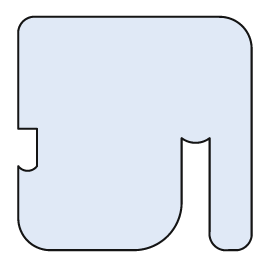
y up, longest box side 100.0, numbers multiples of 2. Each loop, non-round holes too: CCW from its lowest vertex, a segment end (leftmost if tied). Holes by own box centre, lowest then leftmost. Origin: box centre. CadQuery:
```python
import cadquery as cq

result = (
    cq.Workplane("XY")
    .moveTo(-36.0, -50.0)
    .lineTo(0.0, -50.0)
    .threePointArc((14.0, -44.0), (20.0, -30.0))
    .lineTo(20.0, -2.0)
    .threePointArc((26.0, -4.0), (32.0, -2.0))
    .lineTo(32.0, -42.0)
    .threePointArc((34.0, -48.0), (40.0, -50.0))
    .lineTo(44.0, -50.0)
    .threePointArc((48.0, -48.0), (50.0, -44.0))
    .lineTo(50.0, 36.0)
    .threePointArc((46.0, 46.0), (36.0, 50.0))
    .lineTo(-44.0, 50.0)
    .threePointArc((-48.0, 48.0), (-50.0, 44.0))
    .lineTo(-50.0, 2.0)
    .lineTo(-42.0, 2.0)
    .lineTo(-42.0, -14.0)
    .threePointArc((-46.0, -16.0), (-50.0, -14.0))
    .lineTo(-50.0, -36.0)
    .threePointArc((-46.0, -46.0), (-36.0, -50.0))
    .close()
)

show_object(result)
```